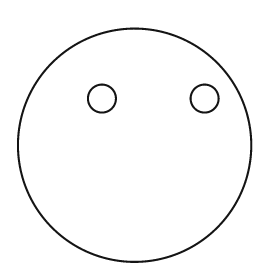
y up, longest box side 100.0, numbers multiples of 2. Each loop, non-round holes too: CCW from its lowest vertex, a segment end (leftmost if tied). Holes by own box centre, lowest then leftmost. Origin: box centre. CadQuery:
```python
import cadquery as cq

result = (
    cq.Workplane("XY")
    .moveTo(0.0, 0.0)
    .circle(50.0)
    .moveTo(-14.0, 20.0)
    .circle(6.0)
    .moveTo(30.0, 20.0)
    .circle(6.0)
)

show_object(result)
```